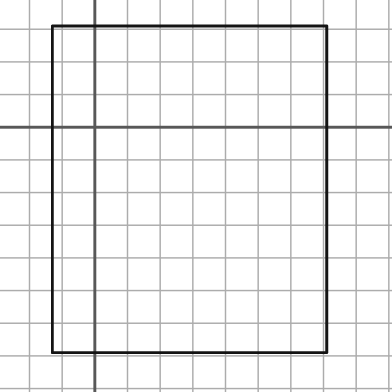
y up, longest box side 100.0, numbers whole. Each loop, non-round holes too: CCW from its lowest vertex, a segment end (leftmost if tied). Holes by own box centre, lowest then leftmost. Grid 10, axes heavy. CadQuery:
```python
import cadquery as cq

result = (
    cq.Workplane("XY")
    .moveTo(-13.0, -69.0)
    .lineTo(71.0, -69.0)
    .lineTo(71.0, 31.0)
    .lineTo(-13.0, 31.0)
    .close()
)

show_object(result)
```